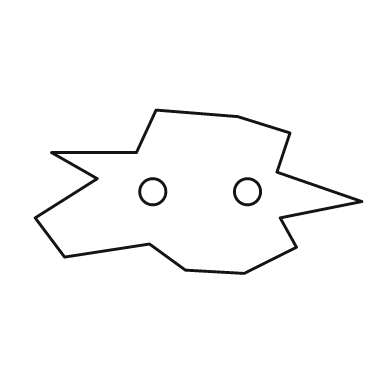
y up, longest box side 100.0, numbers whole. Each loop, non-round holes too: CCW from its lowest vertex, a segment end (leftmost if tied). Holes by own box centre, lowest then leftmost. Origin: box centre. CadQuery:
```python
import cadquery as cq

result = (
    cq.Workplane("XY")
    .moveTo(14.0, -25.0)
    .lineTo(30.0, -17.0)
    .lineTo(25.0, -8.0)
    .lineTo(50.0, -3.0)
    .lineTo(24.0, 6.0)
    .lineTo(28.0, 18.0)
    .lineTo(12.0, 23.0)
    .lineTo(-13.0, 25.0)
    .lineTo(-19.0, 12.0)
    .lineTo(-45.0, 12.0)
    .lineTo(-31.0, 4.0)
    .lineTo(-50.0, -8.0)
    .lineTo(-41.0, -20.0)
    .lineTo(-15.0, -16.0)
    .lineTo(-4.0, -24.0)
    .close()
    .moveTo(-14.0, 0.0)
    .circle(4.0)
    .moveTo(15.0, 0.0)
    .circle(4.0)
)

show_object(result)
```